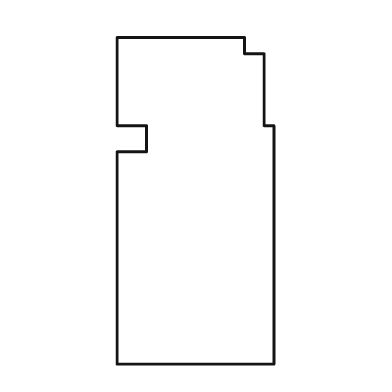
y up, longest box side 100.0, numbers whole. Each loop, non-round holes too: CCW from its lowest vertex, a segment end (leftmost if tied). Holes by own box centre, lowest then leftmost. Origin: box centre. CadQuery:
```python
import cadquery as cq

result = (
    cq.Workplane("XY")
    .moveTo(-24.0, -50.0)
    .lineTo(24.0, -50.0)
    .lineTo(24.0, 23.0)
    .lineTo(21.0, 23.0)
    .lineTo(21.0, 45.0)
    .lineTo(15.0, 45.0)
    .lineTo(15.0, 50.0)
    .lineTo(-24.0, 50.0)
    .lineTo(-24.0, 23.0)
    .lineTo(-15.0, 23.0)
    .lineTo(-15.0, 15.0)
    .lineTo(-24.0, 15.0)
    .close()
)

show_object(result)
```